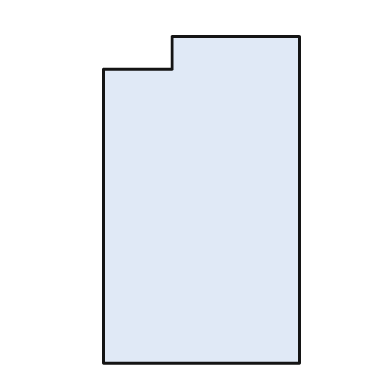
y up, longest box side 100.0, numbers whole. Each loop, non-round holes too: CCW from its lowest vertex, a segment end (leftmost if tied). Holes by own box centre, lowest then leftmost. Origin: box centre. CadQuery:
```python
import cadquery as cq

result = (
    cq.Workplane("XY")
    .moveTo(-30.0, -50.0)
    .lineTo(30.0, -50.0)
    .lineTo(30.0, 50.0)
    .lineTo(-9.0, 50.0)
    .lineTo(-9.0, 40.0)
    .lineTo(-30.0, 40.0)
    .close()
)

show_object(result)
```